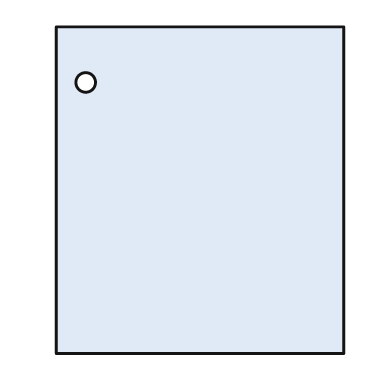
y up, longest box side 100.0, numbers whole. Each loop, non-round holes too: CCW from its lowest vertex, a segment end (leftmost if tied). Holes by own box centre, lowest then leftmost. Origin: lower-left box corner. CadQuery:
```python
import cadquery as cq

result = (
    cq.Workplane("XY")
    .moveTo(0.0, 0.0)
    .lineTo(88.0, 0.0)
    .lineTo(88.0, 100.0)
    .lineTo(0.0, 100.0)
    .close()
    .moveTo(9.0, 83.0)
    .circle(3.0)
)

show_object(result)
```